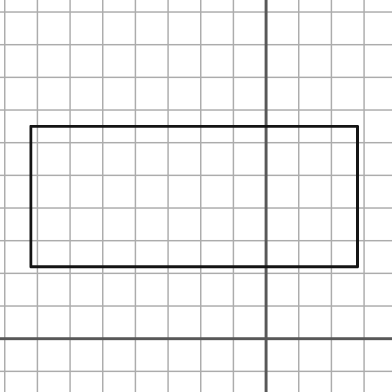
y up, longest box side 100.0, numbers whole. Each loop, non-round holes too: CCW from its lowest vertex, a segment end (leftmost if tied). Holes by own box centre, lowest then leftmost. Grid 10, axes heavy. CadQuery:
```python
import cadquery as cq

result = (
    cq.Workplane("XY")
    .moveTo(-72.0, 22.0)
    .lineTo(28.0, 22.0)
    .lineTo(28.0, 65.0)
    .lineTo(-72.0, 65.0)
    .close()
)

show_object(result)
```